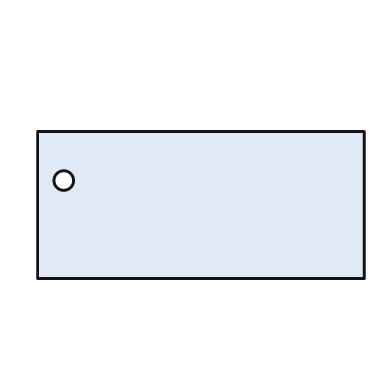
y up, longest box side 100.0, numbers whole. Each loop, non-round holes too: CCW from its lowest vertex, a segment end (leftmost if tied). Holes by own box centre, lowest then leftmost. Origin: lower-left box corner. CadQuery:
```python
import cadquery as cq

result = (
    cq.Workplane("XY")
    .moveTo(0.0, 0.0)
    .lineTo(100.0, 0.0)
    .lineTo(100.0, 45.0)
    .lineTo(0.0, 45.0)
    .close()
    .moveTo(8.0, 30.0)
    .circle(3.0)
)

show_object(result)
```